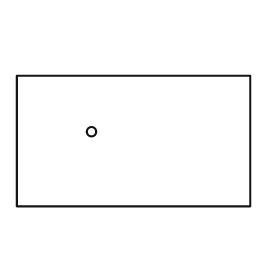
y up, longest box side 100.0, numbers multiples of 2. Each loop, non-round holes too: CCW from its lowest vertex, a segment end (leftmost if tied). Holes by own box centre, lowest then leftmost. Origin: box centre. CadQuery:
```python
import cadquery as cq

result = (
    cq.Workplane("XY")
    .moveTo(-50.0, -28.0)
    .lineTo(50.0, -28.0)
    .lineTo(50.0, 28.0)
    .lineTo(-50.0, 28.0)
    .close()
    .moveTo(-18.0, 4.0)
    .circle(2.0)
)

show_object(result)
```